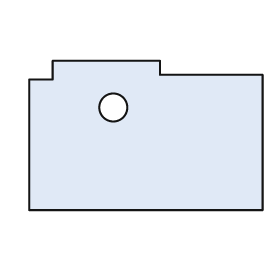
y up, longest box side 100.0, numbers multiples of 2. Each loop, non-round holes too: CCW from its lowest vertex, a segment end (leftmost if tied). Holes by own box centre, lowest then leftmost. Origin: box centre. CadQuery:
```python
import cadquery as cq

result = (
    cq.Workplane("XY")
    .moveTo(-50.0, -32.0)
    .lineTo(50.0, -32.0)
    .lineTo(50.0, 26.0)
    .lineTo(6.0, 26.0)
    .lineTo(6.0, 32.0)
    .lineTo(-40.0, 32.0)
    .lineTo(-40.0, 24.0)
    .lineTo(-50.0, 24.0)
    .close()
    .moveTo(-14.0, 12.0)
    .circle(6.0)
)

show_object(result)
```